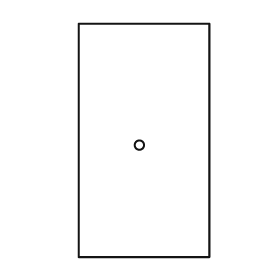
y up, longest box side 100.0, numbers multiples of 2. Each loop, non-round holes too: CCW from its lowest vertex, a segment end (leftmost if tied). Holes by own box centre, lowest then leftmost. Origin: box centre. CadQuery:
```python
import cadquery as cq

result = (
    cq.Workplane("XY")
    .moveTo(-28.0, -50.0)
    .lineTo(28.0, -50.0)
    .lineTo(28.0, 50.0)
    .lineTo(-28.0, 50.0)
    .close()
    .moveTo(-2.0, -2.0)
    .circle(2.0)
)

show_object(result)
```